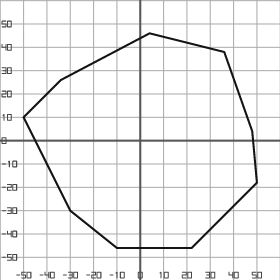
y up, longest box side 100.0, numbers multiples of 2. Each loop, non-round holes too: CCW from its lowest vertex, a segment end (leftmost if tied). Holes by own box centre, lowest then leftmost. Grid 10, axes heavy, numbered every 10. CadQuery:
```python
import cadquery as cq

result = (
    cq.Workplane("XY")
    .moveTo(-10.0, -46.0)
    .lineTo(22.0, -46.0)
    .lineTo(50.0, -18.0)
    .lineTo(48.0, 4.0)
    .lineTo(36.0, 38.0)
    .lineTo(4.0, 46.0)
    .lineTo(-34.0, 26.0)
    .lineTo(-50.0, 10.0)
    .lineTo(-30.0, -30.0)
    .close()
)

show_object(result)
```